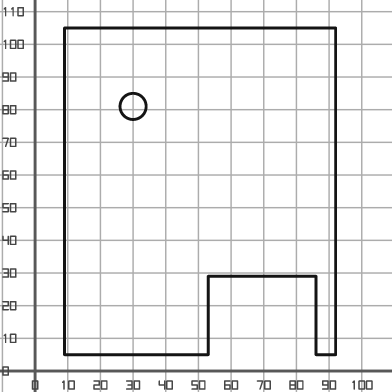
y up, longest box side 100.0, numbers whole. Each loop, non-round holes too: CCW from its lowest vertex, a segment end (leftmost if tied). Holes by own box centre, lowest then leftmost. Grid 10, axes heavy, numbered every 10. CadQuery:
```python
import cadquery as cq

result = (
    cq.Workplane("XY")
    .moveTo(9.0, 5.0)
    .lineTo(53.0, 5.0)
    .lineTo(53.0, 29.0)
    .lineTo(86.0, 29.0)
    .lineTo(86.0, 5.0)
    .lineTo(92.0, 5.0)
    .lineTo(92.0, 105.0)
    .lineTo(9.0, 105.0)
    .close()
    .moveTo(30.0, 81.0)
    .circle(4.0)
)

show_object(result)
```